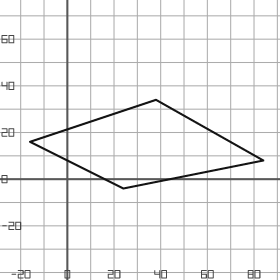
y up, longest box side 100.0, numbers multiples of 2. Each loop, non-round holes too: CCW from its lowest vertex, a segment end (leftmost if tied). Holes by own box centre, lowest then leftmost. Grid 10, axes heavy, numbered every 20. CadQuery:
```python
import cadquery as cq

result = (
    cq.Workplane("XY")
    .moveTo(24.0, -4.0)
    .lineTo(84.0, 8.0)
    .lineTo(38.0, 34.0)
    .lineTo(-16.0, 16.0)
    .close()
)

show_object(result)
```